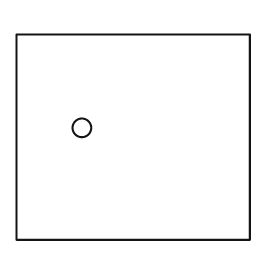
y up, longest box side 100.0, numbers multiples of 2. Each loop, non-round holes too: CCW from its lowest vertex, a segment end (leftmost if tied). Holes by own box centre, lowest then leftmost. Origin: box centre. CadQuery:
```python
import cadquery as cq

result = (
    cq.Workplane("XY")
    .moveTo(-50.0, -44.0)
    .lineTo(50.0, -44.0)
    .lineTo(50.0, 44.0)
    .lineTo(-50.0, 44.0)
    .close()
    .moveTo(-22.0, 4.0)
    .circle(4.0)
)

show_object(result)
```